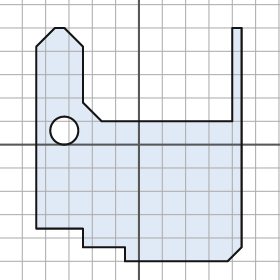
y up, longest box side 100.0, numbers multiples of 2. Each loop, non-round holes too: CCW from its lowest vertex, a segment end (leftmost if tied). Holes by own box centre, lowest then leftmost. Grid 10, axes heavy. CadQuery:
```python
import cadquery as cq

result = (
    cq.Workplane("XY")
    .moveTo(-6.0, -50.0)
    .lineTo(38.0, -50.0)
    .lineTo(44.0, -44.0)
    .lineTo(44.0, 50.0)
    .lineTo(40.0, 50.0)
    .lineTo(40.0, 10.0)
    .lineTo(-16.0, 10.0)
    .lineTo(-24.0, 18.0)
    .lineTo(-24.0, 42.0)
    .lineTo(-32.0, 50.0)
    .lineTo(-36.0, 50.0)
    .lineTo(-44.0, 42.0)
    .lineTo(-44.0, -36.0)
    .lineTo(-24.0, -36.0)
    .lineTo(-24.0, -44.0)
    .lineTo(-6.0, -44.0)
    .close()
    .moveTo(-32.0, 6.0)
    .circle(6.0)
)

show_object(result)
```